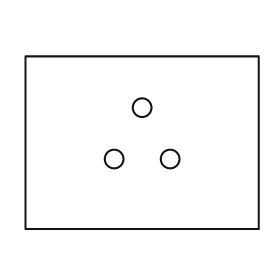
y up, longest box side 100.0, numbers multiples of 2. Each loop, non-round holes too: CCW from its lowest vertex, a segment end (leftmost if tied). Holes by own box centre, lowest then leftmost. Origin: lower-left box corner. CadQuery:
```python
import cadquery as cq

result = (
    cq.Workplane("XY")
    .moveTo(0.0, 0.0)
    .lineTo(100.0, 0.0)
    .lineTo(100.0, 74.0)
    .lineTo(0.0, 74.0)
    .close()
    .moveTo(38.0, 30.0)
    .circle(4.0)
    .moveTo(62.0, 30.0)
    .circle(4.0)
    .moveTo(50.0, 52.0)
    .circle(4.0)
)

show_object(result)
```